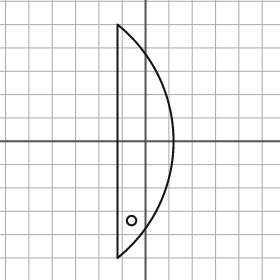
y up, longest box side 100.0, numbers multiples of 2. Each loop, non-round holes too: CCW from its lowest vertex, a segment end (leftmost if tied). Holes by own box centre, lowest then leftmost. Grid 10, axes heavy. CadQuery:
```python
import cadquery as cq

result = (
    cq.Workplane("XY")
    .moveTo(-12.0, -50.0)
    .threePointArc((12.0, 0.0), (-12.0, 50.0))
    .close()
    .moveTo(-6.0, -34.0)
    .circle(2.0)
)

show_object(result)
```